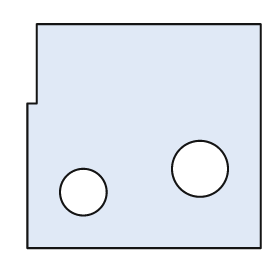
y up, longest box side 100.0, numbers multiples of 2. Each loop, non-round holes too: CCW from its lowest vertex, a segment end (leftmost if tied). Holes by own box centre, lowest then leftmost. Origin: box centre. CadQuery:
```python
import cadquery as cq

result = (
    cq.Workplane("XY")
    .moveTo(-50.0, -48.0)
    .lineTo(50.0, -48.0)
    .lineTo(50.0, 48.0)
    .lineTo(-46.0, 48.0)
    .lineTo(-46.0, 14.0)
    .lineTo(-50.0, 14.0)
    .close()
    .moveTo(-26.0, -24.0)
    .circle(10.0)
    .moveTo(24.0, -14.0)
    .circle(12.0)
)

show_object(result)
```